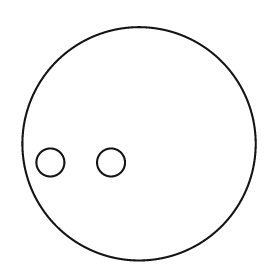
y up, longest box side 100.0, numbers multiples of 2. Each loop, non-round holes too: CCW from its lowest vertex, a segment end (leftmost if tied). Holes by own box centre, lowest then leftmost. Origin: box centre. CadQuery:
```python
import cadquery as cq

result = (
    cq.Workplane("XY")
    .moveTo(0.0, 0.0)
    .circle(50.0)
    .moveTo(-38.0, -8.0)
    .circle(6.0)
    .moveTo(-12.0, -8.0)
    .circle(6.0)
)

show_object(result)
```